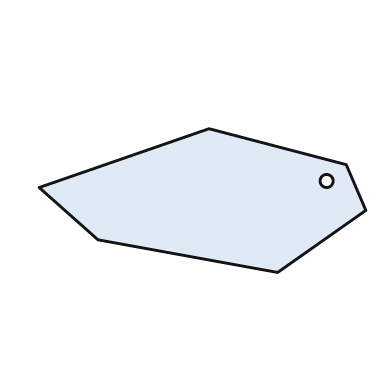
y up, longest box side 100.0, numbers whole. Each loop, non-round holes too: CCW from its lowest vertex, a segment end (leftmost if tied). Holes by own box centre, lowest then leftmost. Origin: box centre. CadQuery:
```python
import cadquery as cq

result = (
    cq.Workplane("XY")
    .moveTo(23.0, -22.0)
    .lineTo(50.0, -3.0)
    .lineTo(44.0, 11.0)
    .lineTo(2.0, 22.0)
    .lineTo(-50.0, 4.0)
    .lineTo(-32.0, -12.0)
    .close()
    .moveTo(38.0, 6.0)
    .circle(2.0)
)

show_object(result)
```